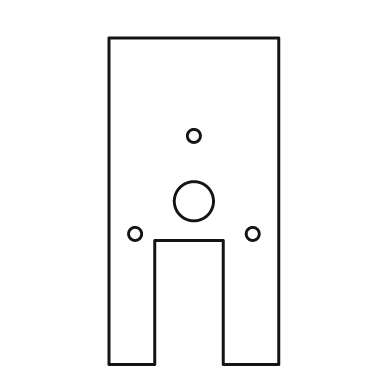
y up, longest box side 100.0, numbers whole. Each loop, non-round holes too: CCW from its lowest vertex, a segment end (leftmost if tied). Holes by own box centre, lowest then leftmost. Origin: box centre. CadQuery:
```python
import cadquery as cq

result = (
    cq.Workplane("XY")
    .moveTo(-26.0, -50.0)
    .lineTo(-12.0, -50.0)
    .lineTo(-12.0, -12.0)
    .lineTo(9.0, -12.0)
    .lineTo(9.0, -50.0)
    .lineTo(26.0, -50.0)
    .lineTo(26.0, 50.0)
    .lineTo(-26.0, 50.0)
    .close()
    .moveTo(-18.0, -10.0)
    .circle(2.0)
    .moveTo(18.0, -10.0)
    .circle(2.0)
    .moveTo(0.0, 0.0)
    .circle(6.0)
    .moveTo(0.0, 20.0)
    .circle(2.0)
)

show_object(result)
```